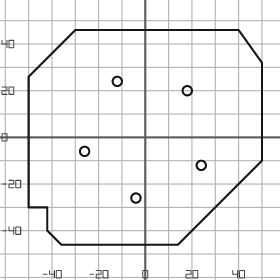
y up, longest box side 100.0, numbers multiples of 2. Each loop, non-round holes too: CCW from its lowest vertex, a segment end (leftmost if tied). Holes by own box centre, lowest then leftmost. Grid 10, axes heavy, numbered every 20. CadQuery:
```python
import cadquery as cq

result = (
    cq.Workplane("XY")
    .moveTo(-36.0, -46.0)
    .lineTo(14.0, -46.0)
    .lineTo(50.0, -10.0)
    .lineTo(50.0, 32.0)
    .lineTo(40.0, 46.0)
    .lineTo(-30.0, 46.0)
    .lineTo(-50.0, 26.0)
    .lineTo(-50.0, -30.0)
    .lineTo(-42.0, -30.0)
    .lineTo(-42.0, -40.0)
    .close()
    .moveTo(-4.0, -26.0)
    .circle(2.0)
    .moveTo(24.0, -12.0)
    .circle(2.0)
    .moveTo(-26.0, -6.0)
    .circle(2.0)
    .moveTo(18.0, 20.0)
    .circle(2.0)
    .moveTo(-12.0, 24.0)
    .circle(2.0)
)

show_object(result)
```